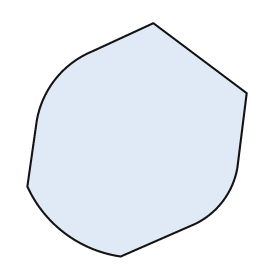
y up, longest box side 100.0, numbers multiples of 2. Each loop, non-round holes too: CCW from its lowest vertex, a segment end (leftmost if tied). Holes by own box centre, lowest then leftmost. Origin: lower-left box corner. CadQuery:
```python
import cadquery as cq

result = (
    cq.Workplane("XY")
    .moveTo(40.0, 0.0)
    .lineTo(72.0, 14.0)
    .threePointArc((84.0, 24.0), (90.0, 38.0))
    .lineTo(94.0, 70.0)
    .lineTo(54.0, 100.0)
    .lineTo(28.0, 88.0)
    .threePointArc((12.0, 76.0), (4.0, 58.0))
    .lineTo(0.0, 30.0)
    .threePointArc((16.0, 10.0), (40.0, 0.0))
    .close()
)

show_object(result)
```